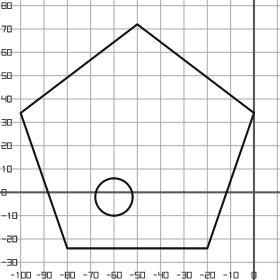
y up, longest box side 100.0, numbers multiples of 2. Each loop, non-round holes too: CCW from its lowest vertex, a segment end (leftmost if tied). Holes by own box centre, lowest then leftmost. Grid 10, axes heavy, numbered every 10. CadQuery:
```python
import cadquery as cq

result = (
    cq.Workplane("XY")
    .moveTo(-80.0, -24.0)
    .lineTo(-20.0, -24.0)
    .lineTo(0.0, 34.0)
    .lineTo(-50.0, 72.0)
    .lineTo(-100.0, 34.0)
    .close()
    .moveTo(-60.0, -2.0)
    .circle(8.0)
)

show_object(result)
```